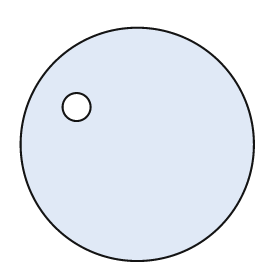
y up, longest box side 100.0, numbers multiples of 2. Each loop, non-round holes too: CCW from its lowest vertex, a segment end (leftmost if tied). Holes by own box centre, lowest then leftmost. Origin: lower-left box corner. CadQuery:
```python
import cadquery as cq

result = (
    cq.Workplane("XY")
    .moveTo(50.0, 50.0)
    .circle(50.0)
    .moveTo(24.0, 66.0)
    .circle(6.0)
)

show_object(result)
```